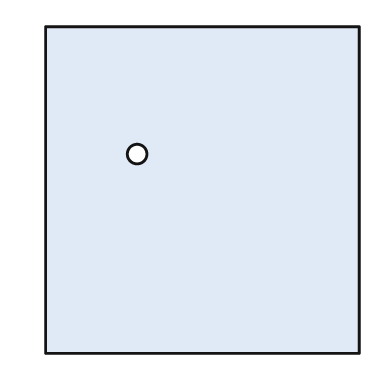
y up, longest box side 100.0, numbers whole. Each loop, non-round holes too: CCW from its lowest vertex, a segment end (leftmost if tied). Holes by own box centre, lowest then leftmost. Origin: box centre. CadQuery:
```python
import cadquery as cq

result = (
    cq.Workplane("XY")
    .moveTo(-48.0, -50.0)
    .lineTo(48.0, -50.0)
    .lineTo(48.0, 50.0)
    .lineTo(-48.0, 50.0)
    .close()
    .moveTo(-20.0, 11.0)
    .circle(3.0)
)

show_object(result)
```